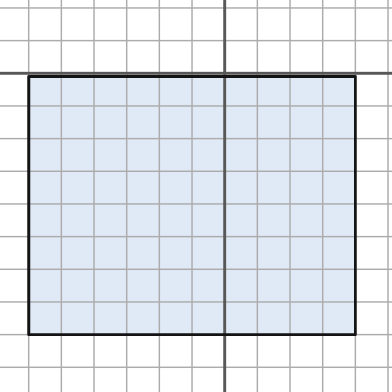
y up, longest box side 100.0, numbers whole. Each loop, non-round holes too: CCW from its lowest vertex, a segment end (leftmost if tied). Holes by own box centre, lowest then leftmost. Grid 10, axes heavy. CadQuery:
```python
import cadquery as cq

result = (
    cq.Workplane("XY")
    .moveTo(-60.0, -80.0)
    .lineTo(40.0, -80.0)
    .lineTo(40.0, -1.0)
    .lineTo(-60.0, -1.0)
    .close()
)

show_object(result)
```